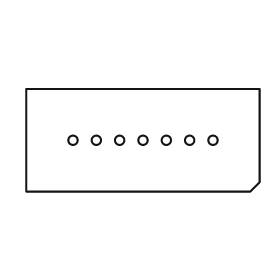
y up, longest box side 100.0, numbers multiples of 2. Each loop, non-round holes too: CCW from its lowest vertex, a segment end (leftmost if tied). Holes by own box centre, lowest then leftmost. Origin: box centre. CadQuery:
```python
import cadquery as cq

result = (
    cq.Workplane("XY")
    .moveTo(-50.0, -22.0)
    .lineTo(46.0, -22.0)
    .lineTo(50.0, -18.0)
    .lineTo(50.0, 22.0)
    .lineTo(-50.0, 22.0)
    .close()
    .moveTo(-30.0, 0.0)
    .circle(2.0)
    .moveTo(-20.0, 0.0)
    .circle(2.0)
    .moveTo(-10.0, 0.0)
    .circle(2.0)
    .moveTo(0.0, 0.0)
    .circle(2.0)
    .moveTo(10.0, 0.0)
    .circle(2.0)
    .moveTo(20.0, 0.0)
    .circle(2.0)
    .moveTo(30.0, 0.0)
    .circle(2.0)
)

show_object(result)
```